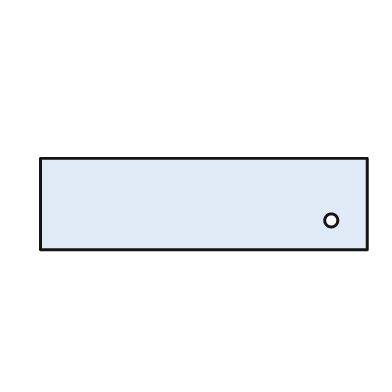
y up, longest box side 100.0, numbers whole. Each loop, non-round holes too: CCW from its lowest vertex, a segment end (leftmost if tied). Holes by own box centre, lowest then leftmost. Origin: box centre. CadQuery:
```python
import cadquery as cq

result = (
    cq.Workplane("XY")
    .moveTo(-50.0, -14.0)
    .lineTo(50.0, -14.0)
    .lineTo(50.0, 14.0)
    .lineTo(-50.0, 14.0)
    .close()
    .moveTo(39.0, -5.0)
    .circle(2.0)
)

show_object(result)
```